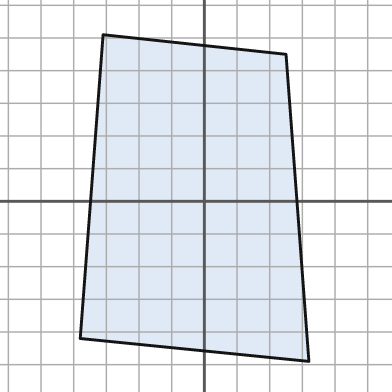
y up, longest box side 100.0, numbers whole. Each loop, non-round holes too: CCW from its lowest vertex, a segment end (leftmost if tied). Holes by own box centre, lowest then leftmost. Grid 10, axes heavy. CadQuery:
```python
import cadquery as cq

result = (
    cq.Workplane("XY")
    .moveTo(32.0, -49.0)
    .lineTo(25.0, 45.0)
    .lineTo(-31.0, 51.0)
    .lineTo(-38.0, -42.0)
    .close()
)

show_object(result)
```